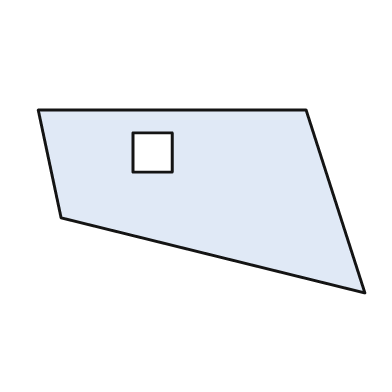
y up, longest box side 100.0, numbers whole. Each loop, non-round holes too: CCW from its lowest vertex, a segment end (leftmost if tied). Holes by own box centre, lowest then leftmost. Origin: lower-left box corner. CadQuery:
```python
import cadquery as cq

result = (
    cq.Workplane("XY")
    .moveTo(100.0, 0.0)
    .lineTo(82.0, 56.0)
    .lineTo(0.0, 56.0)
    .lineTo(7.0, 23.0)
    .close()
    .moveTo(29.0, 37.0)
    .lineTo(41.0, 37.0)
    .lineTo(41.0, 49.0)
    .lineTo(29.0, 49.0)
    .close()
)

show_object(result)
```